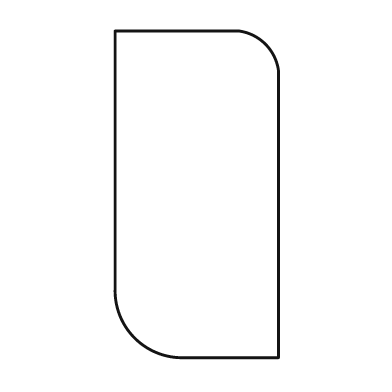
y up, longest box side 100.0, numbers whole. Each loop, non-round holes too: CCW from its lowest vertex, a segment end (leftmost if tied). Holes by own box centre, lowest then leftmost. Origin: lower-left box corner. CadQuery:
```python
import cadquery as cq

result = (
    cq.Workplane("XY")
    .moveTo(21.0, 0.0)
    .lineTo(50.0, 0.0)
    .lineTo(50.0, 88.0)
    .threePointArc((46.0, 96.0), (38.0, 100.0))
    .lineTo(0.0, 100.0)
    .lineTo(0.0, 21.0)
    .threePointArc((6.0, 6.0), (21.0, 0.0))
    .close()
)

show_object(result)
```